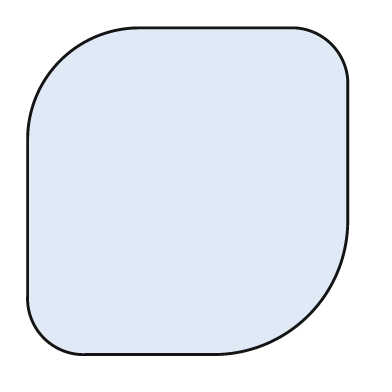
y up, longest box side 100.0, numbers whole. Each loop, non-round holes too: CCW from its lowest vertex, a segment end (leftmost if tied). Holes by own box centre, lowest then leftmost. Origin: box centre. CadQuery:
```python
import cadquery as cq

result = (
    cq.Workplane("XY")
    .moveTo(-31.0, -50.0)
    .lineTo(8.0, -50.0)
    .threePointArc((37.0, -38.0), (49.0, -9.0))
    .lineTo(49.0, 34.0)
    .threePointArc((44.0, 45.0), (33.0, 50.0))
    .lineTo(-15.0, 50.0)
    .threePointArc((-39.0, 40.0), (-49.0, 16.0))
    .lineTo(-49.0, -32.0)
    .threePointArc((-44.0, -45.0), (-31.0, -50.0))
    .close()
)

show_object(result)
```